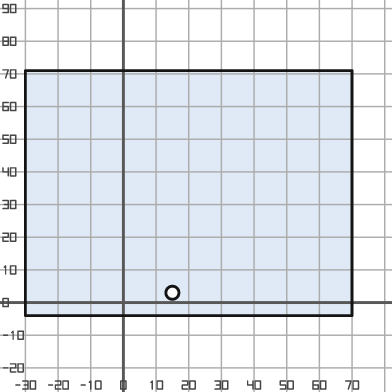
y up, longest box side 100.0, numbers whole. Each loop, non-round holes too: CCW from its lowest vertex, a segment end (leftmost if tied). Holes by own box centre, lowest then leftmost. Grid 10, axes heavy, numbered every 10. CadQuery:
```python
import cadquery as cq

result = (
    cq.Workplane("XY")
    .moveTo(-30.0, -4.0)
    .lineTo(70.0, -4.0)
    .lineTo(70.0, 71.0)
    .lineTo(-30.0, 71.0)
    .close()
    .moveTo(15.0, 3.0)
    .circle(2.0)
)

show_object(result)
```